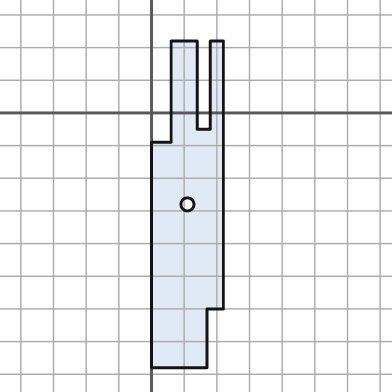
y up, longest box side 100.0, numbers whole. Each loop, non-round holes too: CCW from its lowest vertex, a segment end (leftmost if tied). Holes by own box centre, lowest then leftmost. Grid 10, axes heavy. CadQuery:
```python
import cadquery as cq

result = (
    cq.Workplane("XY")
    .moveTo(0.0, -78.0)
    .lineTo(17.0, -78.0)
    .lineTo(17.0, -60.0)
    .lineTo(22.0, -60.0)
    .lineTo(22.0, 22.0)
    .lineTo(18.0, 22.0)
    .lineTo(18.0, -5.0)
    .lineTo(14.0, -5.0)
    .lineTo(14.0, 22.0)
    .lineTo(6.0, 22.0)
    .lineTo(6.0, -9.0)
    .lineTo(0.0, -9.0)
    .close()
    .moveTo(11.0, -28.0)
    .circle(2.0)
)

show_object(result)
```